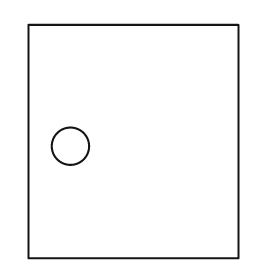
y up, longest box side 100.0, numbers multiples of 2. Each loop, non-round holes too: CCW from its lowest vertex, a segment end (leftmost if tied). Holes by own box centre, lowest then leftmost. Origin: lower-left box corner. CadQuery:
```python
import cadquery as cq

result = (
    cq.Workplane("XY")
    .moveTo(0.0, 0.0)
    .lineTo(90.0, 0.0)
    .lineTo(90.0, 100.0)
    .lineTo(0.0, 100.0)
    .close()
    .moveTo(18.0, 48.0)
    .circle(8.0)
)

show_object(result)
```